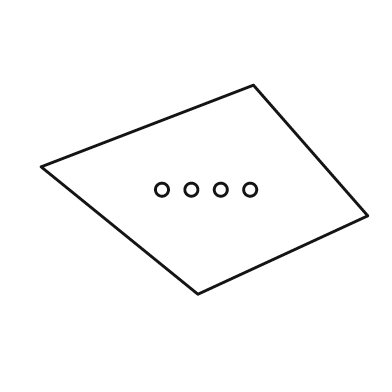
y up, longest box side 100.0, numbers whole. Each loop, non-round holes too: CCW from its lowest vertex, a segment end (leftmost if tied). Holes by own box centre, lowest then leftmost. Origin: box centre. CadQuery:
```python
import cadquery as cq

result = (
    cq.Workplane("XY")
    .moveTo(-2.0, -32.0)
    .lineTo(50.0, -8.0)
    .lineTo(15.0, 32.0)
    .lineTo(-50.0, 7.0)
    .close()
    .moveTo(-13.0, 0.0)
    .circle(2.0)
    .moveTo(-4.0, 0.0)
    .circle(2.0)
    .moveTo(5.0, 0.0)
    .circle(2.0)
    .moveTo(14.0, 0.0)
    .circle(2.0)
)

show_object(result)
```